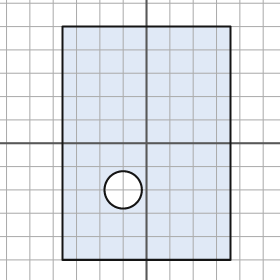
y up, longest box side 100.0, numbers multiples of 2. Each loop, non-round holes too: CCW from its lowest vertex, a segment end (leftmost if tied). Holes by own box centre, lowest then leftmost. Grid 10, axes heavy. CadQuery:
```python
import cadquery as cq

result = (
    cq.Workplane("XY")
    .moveTo(-36.0, -50.0)
    .lineTo(36.0, -50.0)
    .lineTo(36.0, 50.0)
    .lineTo(-36.0, 50.0)
    .close()
    .moveTo(-10.0, -20.0)
    .circle(8.0)
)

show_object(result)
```